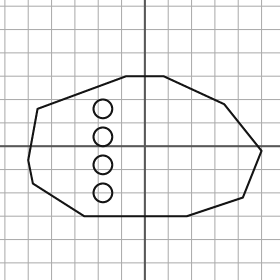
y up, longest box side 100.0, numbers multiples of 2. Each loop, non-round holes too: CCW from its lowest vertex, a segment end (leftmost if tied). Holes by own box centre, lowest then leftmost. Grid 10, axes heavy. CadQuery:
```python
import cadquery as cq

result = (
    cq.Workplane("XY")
    .moveTo(-26.0, -30.0)
    .lineTo(18.0, -30.0)
    .lineTo(42.0, -22.0)
    .lineTo(50.0, -2.0)
    .lineTo(34.0, 18.0)
    .lineTo(8.0, 30.0)
    .lineTo(-8.0, 30.0)
    .lineTo(-46.0, 16.0)
    .lineTo(-50.0, -6.0)
    .lineTo(-48.0, -16.0)
    .close()
    .moveTo(-18.0, -20.0)
    .circle(4.0)
    .moveTo(-18.0, -8.0)
    .circle(4.0)
    .moveTo(-18.0, 4.0)
    .circle(4.0)
    .moveTo(-18.0, 16.0)
    .circle(4.0)
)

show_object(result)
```